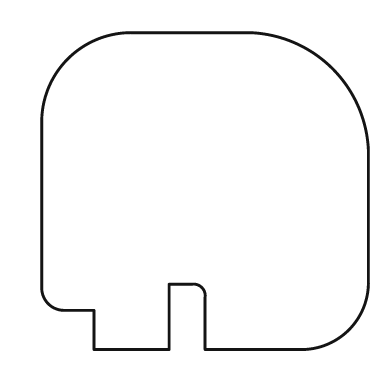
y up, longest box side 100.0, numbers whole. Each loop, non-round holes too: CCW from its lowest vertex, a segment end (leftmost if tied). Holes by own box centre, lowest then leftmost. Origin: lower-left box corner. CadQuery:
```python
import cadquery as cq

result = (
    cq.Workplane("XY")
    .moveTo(16.0, 0.0)
    .lineTo(39.0, 0.0)
    .lineTo(39.0, 20.0)
    .lineTo(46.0, 20.0)
    .threePointArc((49.0, 19.0), (50.0, 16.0))
    .lineTo(50.0, 0.0)
    .lineTo(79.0, 0.0)
    .threePointArc((94.0, 6.0), (100.0, 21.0))
    .lineTo(100.0, 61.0)
    .threePointArc((89.0, 86.0), (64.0, 97.0))
    .lineTo(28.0, 97.0)
    .threePointArc((8.0, 89.0), (0.0, 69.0))
    .lineTo(0.0, 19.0)
    .threePointArc((2.0, 14.0), (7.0, 12.0))
    .lineTo(16.0, 12.0)
    .close()
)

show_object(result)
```